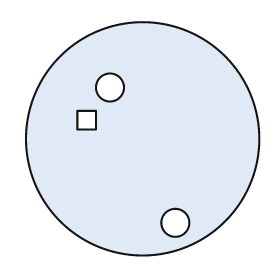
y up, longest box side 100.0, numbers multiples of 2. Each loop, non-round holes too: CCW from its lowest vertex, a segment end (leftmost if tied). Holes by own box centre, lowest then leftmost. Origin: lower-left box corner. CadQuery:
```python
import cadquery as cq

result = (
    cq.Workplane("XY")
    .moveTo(50.0, 50.0)
    .circle(50.0)
    .moveTo(64.0, 14.0)
    .circle(6.0)
    .moveTo(22.0, 54.0)
    .lineTo(30.0, 54.0)
    .lineTo(30.0, 62.0)
    .lineTo(22.0, 62.0)
    .close()
    .moveTo(36.0, 72.0)
    .circle(6.0)
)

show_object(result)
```